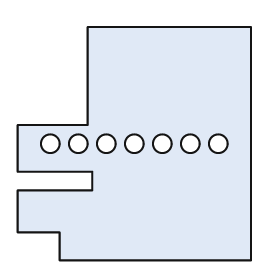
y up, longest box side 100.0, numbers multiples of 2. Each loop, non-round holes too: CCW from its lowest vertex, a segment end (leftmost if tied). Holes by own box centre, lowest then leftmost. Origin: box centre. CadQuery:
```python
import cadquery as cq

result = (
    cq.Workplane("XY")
    .moveTo(-32.0, -50.0)
    .lineTo(50.0, -50.0)
    .lineTo(50.0, 50.0)
    .lineTo(-20.0, 50.0)
    .lineTo(-20.0, 8.0)
    .lineTo(-50.0, 8.0)
    .lineTo(-50.0, -12.0)
    .lineTo(-18.0, -12.0)
    .lineTo(-18.0, -20.0)
    .lineTo(-50.0, -20.0)
    .lineTo(-50.0, -38.0)
    .lineTo(-32.0, -38.0)
    .close()
    .moveTo(-36.0, 0.0)
    .circle(4.0)
    .moveTo(-24.0, 0.0)
    .circle(4.0)
    .moveTo(-12.0, 0.0)
    .circle(4.0)
    .moveTo(0.0, 0.0)
    .circle(4.0)
    .moveTo(12.0, 0.0)
    .circle(4.0)
    .moveTo(24.0, 0.0)
    .circle(4.0)
    .moveTo(36.0, 0.0)
    .circle(4.0)
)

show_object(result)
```